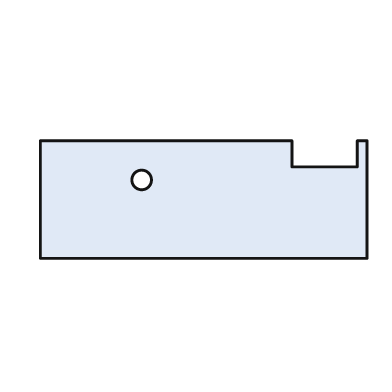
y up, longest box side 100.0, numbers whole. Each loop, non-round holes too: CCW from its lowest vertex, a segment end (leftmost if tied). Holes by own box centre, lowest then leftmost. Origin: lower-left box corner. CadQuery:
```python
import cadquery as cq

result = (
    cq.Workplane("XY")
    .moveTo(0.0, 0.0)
    .lineTo(100.0, 0.0)
    .lineTo(100.0, 36.0)
    .lineTo(97.0, 36.0)
    .lineTo(97.0, 28.0)
    .lineTo(77.0, 28.0)
    .lineTo(77.0, 36.0)
    .lineTo(0.0, 36.0)
    .close()
    .moveTo(31.0, 24.0)
    .circle(3.0)
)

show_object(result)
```